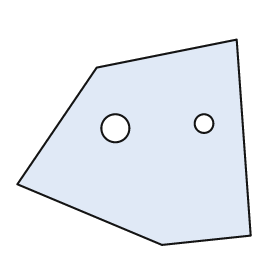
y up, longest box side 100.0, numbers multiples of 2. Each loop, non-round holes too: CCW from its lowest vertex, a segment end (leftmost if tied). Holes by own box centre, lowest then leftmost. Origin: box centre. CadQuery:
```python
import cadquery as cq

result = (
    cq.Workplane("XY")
    .moveTo(12.0, -44.0)
    .lineTo(50.0, -40.0)
    .lineTo(44.0, 44.0)
    .lineTo(-16.0, 32.0)
    .lineTo(-50.0, -18.0)
    .close()
    .moveTo(-8.0, 6.0)
    .circle(6.0)
    .moveTo(30.0, 8.0)
    .circle(4.0)
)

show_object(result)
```